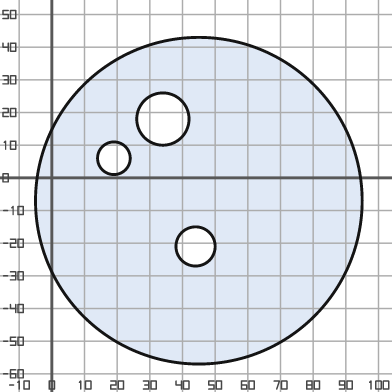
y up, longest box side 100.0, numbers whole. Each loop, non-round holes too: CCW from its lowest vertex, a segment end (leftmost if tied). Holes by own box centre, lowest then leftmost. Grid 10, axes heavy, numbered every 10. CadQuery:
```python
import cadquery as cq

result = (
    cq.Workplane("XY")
    .moveTo(45.0, -7.0)
    .circle(50.0)
    .moveTo(44.0, -21.0)
    .circle(6.0)
    .moveTo(19.0, 6.0)
    .circle(5.0)
    .moveTo(34.0, 18.0)
    .circle(8.0)
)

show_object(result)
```